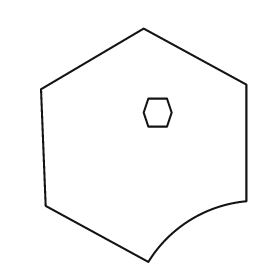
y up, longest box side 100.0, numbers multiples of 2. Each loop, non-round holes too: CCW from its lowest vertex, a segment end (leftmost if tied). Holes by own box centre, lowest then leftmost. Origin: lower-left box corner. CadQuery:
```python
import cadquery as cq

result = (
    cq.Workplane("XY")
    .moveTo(46.0, 0.0)
    .threePointArc((64.0, 18.0), (88.0, 26.0))
    .lineTo(88.0, 76.0)
    .lineTo(44.0, 100.0)
    .lineTo(0.0, 74.0)
    .lineTo(2.0, 24.0)
    .close()
    .moveTo(46.0, 58.0)
    .lineTo(54.0, 58.0)
    .lineTo(56.0, 64.0)
    .lineTo(54.0, 70.0)
    .lineTo(46.0, 70.0)
    .lineTo(44.0, 64.0)
    .close()
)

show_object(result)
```